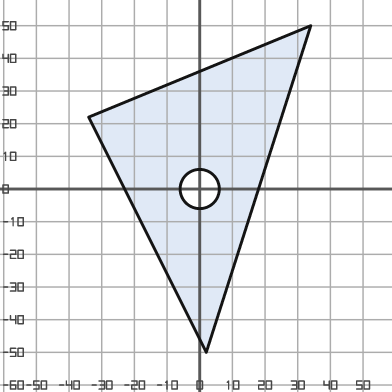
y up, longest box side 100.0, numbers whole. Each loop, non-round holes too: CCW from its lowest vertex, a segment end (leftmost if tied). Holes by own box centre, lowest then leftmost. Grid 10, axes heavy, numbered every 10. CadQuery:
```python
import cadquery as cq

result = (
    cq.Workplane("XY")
    .moveTo(2.0, -50.0)
    .lineTo(34.0, 50.0)
    .lineTo(-34.0, 22.0)
    .close()
    .moveTo(0.0, 0.0)
    .circle(6.0)
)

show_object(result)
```